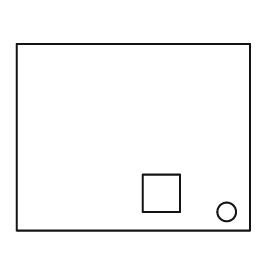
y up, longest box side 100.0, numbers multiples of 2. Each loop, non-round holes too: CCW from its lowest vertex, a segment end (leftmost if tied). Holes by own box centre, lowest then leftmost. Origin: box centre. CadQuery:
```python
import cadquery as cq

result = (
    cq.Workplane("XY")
    .moveTo(-50.0, -40.0)
    .lineTo(50.0, -40.0)
    .lineTo(50.0, 40.0)
    .lineTo(-50.0, 40.0)
    .close()
    .moveTo(40.0, -32.0)
    .circle(4.0)
    .moveTo(4.0, -32.0)
    .lineTo(20.0, -32.0)
    .lineTo(20.0, -16.0)
    .lineTo(4.0, -16.0)
    .close()
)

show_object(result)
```